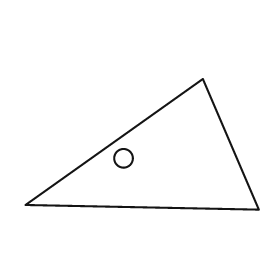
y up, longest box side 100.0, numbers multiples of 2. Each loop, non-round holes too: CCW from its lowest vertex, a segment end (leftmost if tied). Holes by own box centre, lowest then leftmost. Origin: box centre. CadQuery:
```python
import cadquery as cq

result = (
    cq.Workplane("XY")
    .moveTo(50.0, -28.0)
    .lineTo(26.0, 28.0)
    .lineTo(-50.0, -26.0)
    .close()
    .moveTo(-8.0, -6.0)
    .circle(4.0)
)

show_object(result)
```